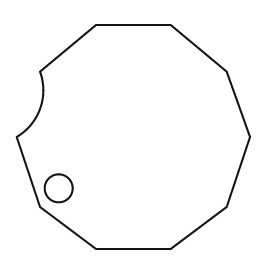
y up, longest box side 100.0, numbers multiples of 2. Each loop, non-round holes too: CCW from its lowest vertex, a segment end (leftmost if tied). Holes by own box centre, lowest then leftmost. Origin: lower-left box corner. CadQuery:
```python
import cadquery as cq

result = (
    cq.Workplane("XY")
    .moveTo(34.0, 0.0)
    .lineTo(66.0, 0.0)
    .lineTo(90.0, 18.0)
    .lineTo(100.0, 48.0)
    .lineTo(90.0, 76.0)
    .lineTo(66.0, 96.0)
    .lineTo(34.0, 96.0)
    .lineTo(10.0, 76.0)
    .threePointArc((10.0, 60.0), (0.0, 48.0))
    .lineTo(10.0, 18.0)
    .close()
    .moveTo(18.0, 26.0)
    .circle(6.0)
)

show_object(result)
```